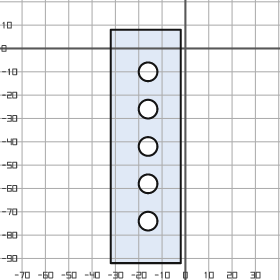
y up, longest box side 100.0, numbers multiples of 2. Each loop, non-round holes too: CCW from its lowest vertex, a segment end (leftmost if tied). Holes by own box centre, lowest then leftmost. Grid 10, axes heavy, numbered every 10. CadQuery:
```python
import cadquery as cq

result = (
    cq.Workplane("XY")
    .moveTo(-32.0, -92.0)
    .lineTo(-2.0, -92.0)
    .lineTo(-2.0, 8.0)
    .lineTo(-32.0, 8.0)
    .close()
    .moveTo(-16.0, -74.0)
    .circle(4.0)
    .moveTo(-16.0, -58.0)
    .circle(4.0)
    .moveTo(-16.0, -42.0)
    .circle(4.0)
    .moveTo(-16.0, -26.0)
    .circle(4.0)
    .moveTo(-16.0, -10.0)
    .circle(4.0)
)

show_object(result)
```